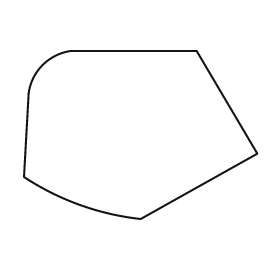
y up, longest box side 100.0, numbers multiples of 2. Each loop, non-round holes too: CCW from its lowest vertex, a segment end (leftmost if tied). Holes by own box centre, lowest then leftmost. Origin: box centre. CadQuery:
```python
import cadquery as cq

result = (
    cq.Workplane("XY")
    .moveTo(0.0, -36.0)
    .lineTo(50.0, -8.0)
    .lineTo(24.0, 36.0)
    .lineTo(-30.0, 36.0)
    .threePointArc((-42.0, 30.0), (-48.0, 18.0))
    .lineTo(-50.0, -18.0)
    .threePointArc((-26.0, -30.0), (0.0, -36.0))
    .close()
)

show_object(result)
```